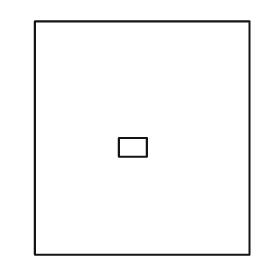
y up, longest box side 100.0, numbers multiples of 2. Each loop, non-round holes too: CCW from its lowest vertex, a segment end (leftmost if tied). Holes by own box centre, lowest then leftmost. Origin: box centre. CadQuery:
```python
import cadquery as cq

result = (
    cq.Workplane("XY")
    .moveTo(-46.0, -50.0)
    .lineTo(46.0, -50.0)
    .lineTo(46.0, 50.0)
    .lineTo(-46.0, 50.0)
    .close()
    .moveTo(-10.0, -8.0)
    .lineTo(2.0, -8.0)
    .lineTo(2.0, 0.0)
    .lineTo(-10.0, 0.0)
    .close()
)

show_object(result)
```